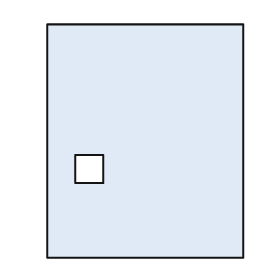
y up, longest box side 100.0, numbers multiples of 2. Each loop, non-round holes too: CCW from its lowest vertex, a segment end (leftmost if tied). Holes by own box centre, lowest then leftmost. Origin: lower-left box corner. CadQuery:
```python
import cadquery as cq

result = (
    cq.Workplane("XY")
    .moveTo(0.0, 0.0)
    .lineTo(84.0, 0.0)
    .lineTo(84.0, 100.0)
    .lineTo(0.0, 100.0)
    .close()
    .moveTo(12.0, 32.0)
    .lineTo(24.0, 32.0)
    .lineTo(24.0, 44.0)
    .lineTo(12.0, 44.0)
    .close()
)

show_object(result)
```